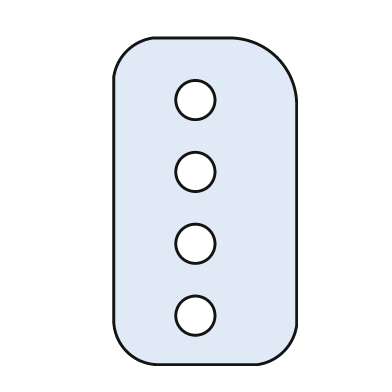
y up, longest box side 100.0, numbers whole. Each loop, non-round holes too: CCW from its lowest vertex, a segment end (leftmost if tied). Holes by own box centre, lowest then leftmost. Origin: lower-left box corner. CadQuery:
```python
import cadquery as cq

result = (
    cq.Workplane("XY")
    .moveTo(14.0, 0.0)
    .lineTo(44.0, 0.0)
    .threePointArc((52.0, 4.0), (56.0, 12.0))
    .lineTo(56.0, 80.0)
    .threePointArc((50.0, 94.0), (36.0, 100.0))
    .lineTo(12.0, 100.0)
    .threePointArc((4.0, 96.0), (0.0, 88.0))
    .lineTo(0.0, 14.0)
    .threePointArc((4.0, 4.0), (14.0, 0.0))
    .close()
    .moveTo(25.0, 15.0)
    .circle(6.0)
    .moveTo(25.0, 37.0)
    .circle(6.0)
    .moveTo(25.0, 59.0)
    .circle(6.0)
    .moveTo(25.0, 81.0)
    .circle(6.0)
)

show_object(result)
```